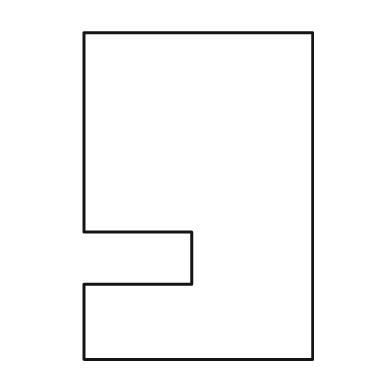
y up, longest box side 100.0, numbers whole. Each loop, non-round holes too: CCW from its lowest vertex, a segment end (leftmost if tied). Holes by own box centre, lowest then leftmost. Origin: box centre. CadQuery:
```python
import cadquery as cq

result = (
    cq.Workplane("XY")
    .moveTo(-35.0, -50.0)
    .lineTo(35.0, -50.0)
    .lineTo(35.0, 50.0)
    .lineTo(-35.0, 50.0)
    .lineTo(-35.0, -11.0)
    .lineTo(-2.0, -11.0)
    .lineTo(-2.0, -27.0)
    .lineTo(-35.0, -27.0)
    .close()
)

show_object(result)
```